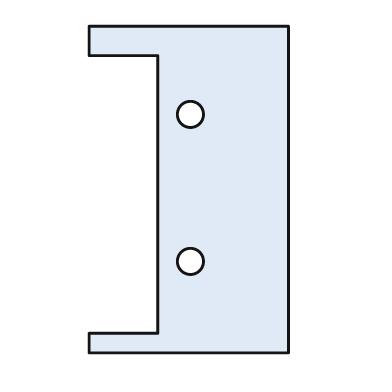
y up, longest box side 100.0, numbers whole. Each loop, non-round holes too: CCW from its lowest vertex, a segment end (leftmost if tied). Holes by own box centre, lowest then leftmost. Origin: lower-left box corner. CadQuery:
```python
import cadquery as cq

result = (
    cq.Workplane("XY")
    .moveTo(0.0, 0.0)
    .lineTo(61.0, 0.0)
    .lineTo(61.0, 100.0)
    .lineTo(0.0, 100.0)
    .lineTo(0.0, 91.0)
    .lineTo(21.0, 91.0)
    .lineTo(21.0, 6.0)
    .lineTo(0.0, 6.0)
    .close()
    .moveTo(31.0, 28.0)
    .circle(4.0)
    .moveTo(31.0, 73.0)
    .circle(4.0)
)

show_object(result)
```